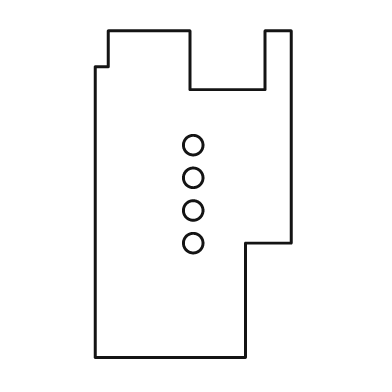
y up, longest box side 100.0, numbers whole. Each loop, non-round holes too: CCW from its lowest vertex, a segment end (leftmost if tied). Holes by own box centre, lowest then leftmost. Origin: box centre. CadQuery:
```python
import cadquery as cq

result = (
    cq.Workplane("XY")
    .moveTo(-30.0, -50.0)
    .lineTo(16.0, -50.0)
    .lineTo(16.0, -15.0)
    .lineTo(30.0, -15.0)
    .lineTo(30.0, 50.0)
    .lineTo(22.0, 50.0)
    .lineTo(22.0, 32.0)
    .lineTo(-1.0, 32.0)
    .lineTo(-1.0, 50.0)
    .lineTo(-26.0, 50.0)
    .lineTo(-26.0, 39.0)
    .lineTo(-30.0, 39.0)
    .close()
    .moveTo(0.0, -15.0)
    .circle(3.0)
    .moveTo(0.0, -5.0)
    .circle(3.0)
    .moveTo(0.0, 5.0)
    .circle(3.0)
    .moveTo(0.0, 15.0)
    .circle(3.0)
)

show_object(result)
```